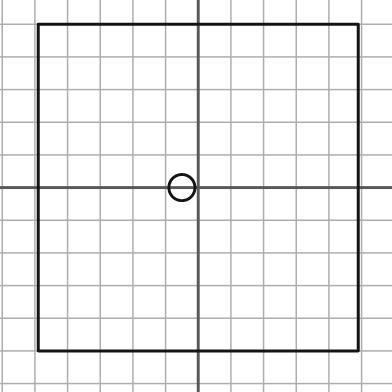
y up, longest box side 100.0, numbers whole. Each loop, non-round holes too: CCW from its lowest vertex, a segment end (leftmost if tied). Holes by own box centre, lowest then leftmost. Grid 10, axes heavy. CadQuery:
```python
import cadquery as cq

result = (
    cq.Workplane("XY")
    .moveTo(-49.0, -50.0)
    .lineTo(49.0, -50.0)
    .lineTo(49.0, 50.0)
    .lineTo(-49.0, 50.0)
    .close()
    .moveTo(-5.0, 0.0)
    .circle(4.0)
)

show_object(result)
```